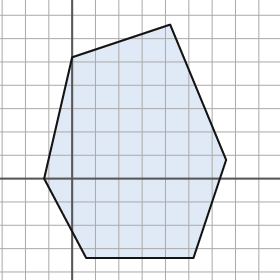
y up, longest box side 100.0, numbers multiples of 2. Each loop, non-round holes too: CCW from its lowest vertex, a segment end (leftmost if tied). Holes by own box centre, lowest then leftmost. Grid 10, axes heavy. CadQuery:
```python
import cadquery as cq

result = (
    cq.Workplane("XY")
    .moveTo(6.0, -34.0)
    .lineTo(52.0, -34.0)
    .lineTo(66.0, 8.0)
    .lineTo(42.0, 66.0)
    .lineTo(0.0, 52.0)
    .lineTo(-12.0, 0.0)
    .close()
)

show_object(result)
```